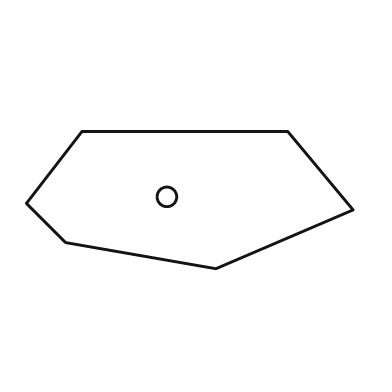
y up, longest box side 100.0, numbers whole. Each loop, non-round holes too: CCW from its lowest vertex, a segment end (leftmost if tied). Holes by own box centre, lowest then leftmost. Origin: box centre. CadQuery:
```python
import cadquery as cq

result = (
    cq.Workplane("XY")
    .moveTo(8.0, -21.0)
    .lineTo(50.0, -3.0)
    .lineTo(30.0, 21.0)
    .lineTo(-33.0, 21.0)
    .lineTo(-50.0, -1.0)
    .lineTo(-38.0, -13.0)
    .close()
    .moveTo(-7.0, 1.0)
    .circle(3.0)
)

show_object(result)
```